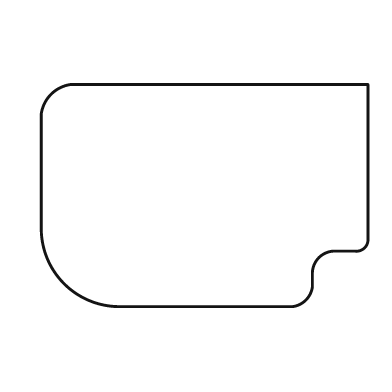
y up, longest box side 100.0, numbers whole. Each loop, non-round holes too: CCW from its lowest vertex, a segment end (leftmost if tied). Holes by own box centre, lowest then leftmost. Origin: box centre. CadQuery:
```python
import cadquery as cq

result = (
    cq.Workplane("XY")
    .moveTo(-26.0, -34.0)
    .lineTo(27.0, -34.0)
    .threePointArc((31.0, -32.0), (33.0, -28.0))
    .lineTo(33.0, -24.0)
    .threePointArc((35.0, -19.0), (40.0, -17.0))
    .lineTo(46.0, -17.0)
    .threePointArc((49.0, -16.0), (50.0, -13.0))
    .lineTo(50.0, 34.0)
    .lineTo(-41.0, 34.0)
    .threePointArc((-47.0, 31.0), (-50.0, 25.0))
    .lineTo(-50.0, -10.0)
    .threePointArc((-43.0, -27.0), (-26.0, -34.0))
    .close()
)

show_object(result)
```